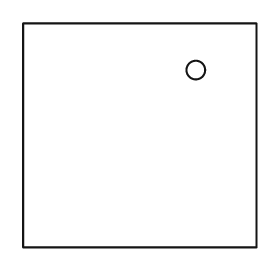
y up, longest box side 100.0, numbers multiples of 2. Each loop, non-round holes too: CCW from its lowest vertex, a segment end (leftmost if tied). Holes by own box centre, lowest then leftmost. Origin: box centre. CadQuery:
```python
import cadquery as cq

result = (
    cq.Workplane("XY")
    .moveTo(-50.0, -48.0)
    .lineTo(50.0, -48.0)
    .lineTo(50.0, 48.0)
    .lineTo(-50.0, 48.0)
    .close()
    .moveTo(24.0, 28.0)
    .circle(4.0)
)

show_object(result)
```